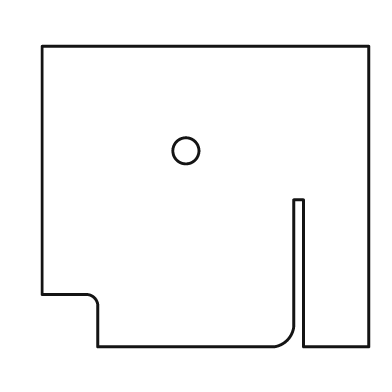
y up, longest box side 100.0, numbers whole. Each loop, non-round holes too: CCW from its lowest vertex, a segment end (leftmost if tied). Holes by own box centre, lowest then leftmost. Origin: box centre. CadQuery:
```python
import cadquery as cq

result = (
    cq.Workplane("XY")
    .moveTo(-33.0, -46.0)
    .lineTo(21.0, -46.0)
    .threePointArc((25.0, -44.0), (27.0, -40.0))
    .lineTo(27.0, -1.0)
    .lineTo(30.0, -1.0)
    .lineTo(30.0, -46.0)
    .lineTo(50.0, -46.0)
    .lineTo(50.0, 46.0)
    .lineTo(-50.0, 46.0)
    .lineTo(-50.0, -30.0)
    .lineTo(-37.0, -30.0)
    .threePointArc((-34.0, -31.0), (-33.0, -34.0))
    .close()
    .moveTo(-6.0, 14.0)
    .circle(4.0)
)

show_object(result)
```